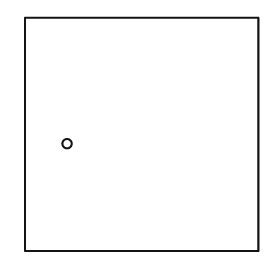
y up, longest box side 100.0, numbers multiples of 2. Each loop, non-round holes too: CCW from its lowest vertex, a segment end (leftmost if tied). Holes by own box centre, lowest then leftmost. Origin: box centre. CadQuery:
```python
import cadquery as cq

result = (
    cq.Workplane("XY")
    .moveTo(-50.0, -50.0)
    .lineTo(50.0, -50.0)
    .lineTo(50.0, 50.0)
    .lineTo(-50.0, 50.0)
    .close()
    .moveTo(-32.0, -4.0)
    .circle(2.0)
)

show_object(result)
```